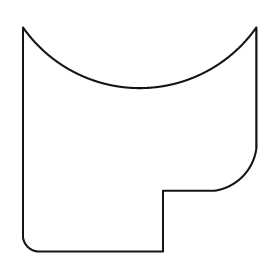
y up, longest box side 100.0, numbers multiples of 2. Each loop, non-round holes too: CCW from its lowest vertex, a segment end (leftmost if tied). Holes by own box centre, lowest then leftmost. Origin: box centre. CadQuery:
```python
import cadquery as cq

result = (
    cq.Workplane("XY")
    .moveTo(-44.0, -48.0)
    .lineTo(10.0, -48.0)
    .lineTo(10.0, -22.0)
    .lineTo(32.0, -22.0)
    .threePointArc((44.0, -16.0), (50.0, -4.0))
    .lineTo(50.0, 48.0)
    .threePointArc((0.0, 22.0), (-50.0, 48.0))
    .lineTo(-50.0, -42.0)
    .threePointArc((-48.0, -46.0), (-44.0, -48.0))
    .close()
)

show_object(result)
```